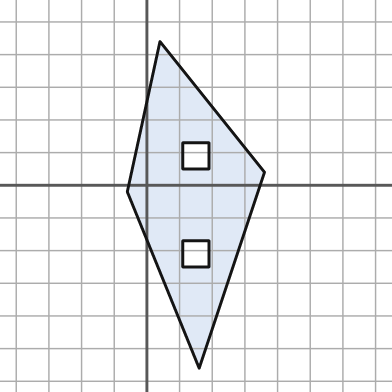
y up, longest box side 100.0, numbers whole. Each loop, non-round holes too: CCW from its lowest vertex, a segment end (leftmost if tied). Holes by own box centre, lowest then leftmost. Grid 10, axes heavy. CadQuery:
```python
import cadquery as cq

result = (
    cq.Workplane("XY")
    .moveTo(16.0, -56.0)
    .lineTo(36.0, 4.0)
    .lineTo(4.0, 44.0)
    .lineTo(-6.0, -2.0)
    .close()
    .moveTo(11.0, -25.0)
    .lineTo(19.0, -25.0)
    .lineTo(19.0, -17.0)
    .lineTo(11.0, -17.0)
    .close()
    .moveTo(11.0, 5.0)
    .lineTo(19.0, 5.0)
    .lineTo(19.0, 13.0)
    .lineTo(11.0, 13.0)
    .close()
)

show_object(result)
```